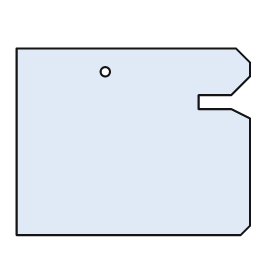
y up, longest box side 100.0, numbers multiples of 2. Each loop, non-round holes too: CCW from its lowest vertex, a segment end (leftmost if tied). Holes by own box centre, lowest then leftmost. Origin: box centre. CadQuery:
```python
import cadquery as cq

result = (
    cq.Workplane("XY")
    .moveTo(-50.0, -40.0)
    .lineTo(46.0, -40.0)
    .lineTo(50.0, -36.0)
    .lineTo(50.0, 10.0)
    .lineTo(42.0, 14.0)
    .lineTo(28.0, 14.0)
    .lineTo(28.0, 20.0)
    .lineTo(42.0, 20.0)
    .lineTo(50.0, 28.0)
    .lineTo(50.0, 34.0)
    .lineTo(44.0, 40.0)
    .lineTo(-50.0, 40.0)
    .close()
    .moveTo(-12.0, 30.0)
    .circle(2.0)
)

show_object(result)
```